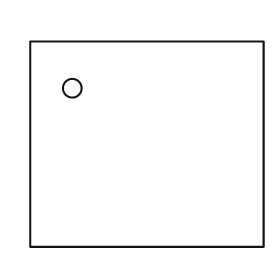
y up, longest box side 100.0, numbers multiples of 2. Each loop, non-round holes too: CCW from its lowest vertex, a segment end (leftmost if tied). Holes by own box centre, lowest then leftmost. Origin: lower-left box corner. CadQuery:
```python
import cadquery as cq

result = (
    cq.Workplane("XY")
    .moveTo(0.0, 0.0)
    .lineTo(100.0, 0.0)
    .lineTo(100.0, 88.0)
    .lineTo(0.0, 88.0)
    .close()
    .moveTo(18.0, 68.0)
    .circle(4.0)
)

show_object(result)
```